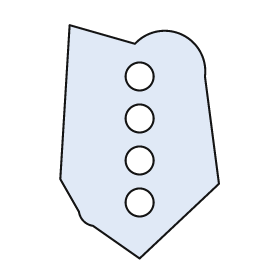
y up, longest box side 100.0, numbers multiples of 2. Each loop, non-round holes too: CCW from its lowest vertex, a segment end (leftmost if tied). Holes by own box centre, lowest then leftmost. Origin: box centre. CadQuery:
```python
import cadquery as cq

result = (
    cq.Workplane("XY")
    .moveTo(0.0, -50.0)
    .lineTo(34.0, -18.0)
    .lineTo(28.0, 28.0)
    .threePointArc((18.0, 46.0), (-2.0, 42.0))
    .lineTo(-30.0, 50.0)
    .lineTo(-34.0, -16.0)
    .lineTo(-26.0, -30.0)
    .threePointArc((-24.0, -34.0), (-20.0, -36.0))
    .close()
    .moveTo(0.0, -26.0)
    .circle(6.0)
    .moveTo(0.0, -8.0)
    .circle(6.0)
    .moveTo(0.0, 10.0)
    .circle(6.0)
    .moveTo(0.0, 28.0)
    .circle(6.0)
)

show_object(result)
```